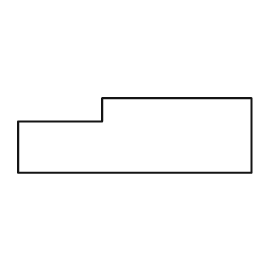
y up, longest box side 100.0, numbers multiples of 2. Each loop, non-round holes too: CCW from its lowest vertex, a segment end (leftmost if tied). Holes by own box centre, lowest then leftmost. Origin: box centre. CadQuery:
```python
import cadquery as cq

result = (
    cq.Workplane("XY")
    .moveTo(-50.0, -16.0)
    .lineTo(50.0, -16.0)
    .lineTo(50.0, 16.0)
    .lineTo(-14.0, 16.0)
    .lineTo(-14.0, 6.0)
    .lineTo(-50.0, 6.0)
    .close()
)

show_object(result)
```